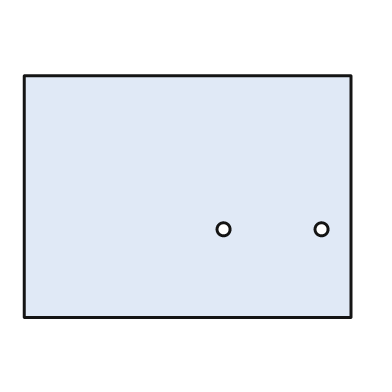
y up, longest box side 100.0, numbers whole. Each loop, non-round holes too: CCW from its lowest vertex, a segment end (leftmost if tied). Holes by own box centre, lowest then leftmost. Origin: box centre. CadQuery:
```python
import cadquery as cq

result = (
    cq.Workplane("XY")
    .moveTo(-50.0, -37.0)
    .lineTo(50.0, -37.0)
    .lineTo(50.0, 37.0)
    .lineTo(-50.0, 37.0)
    .close()
    .moveTo(11.0, -10.0)
    .circle(2.0)
    .moveTo(41.0, -10.0)
    .circle(2.0)
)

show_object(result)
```